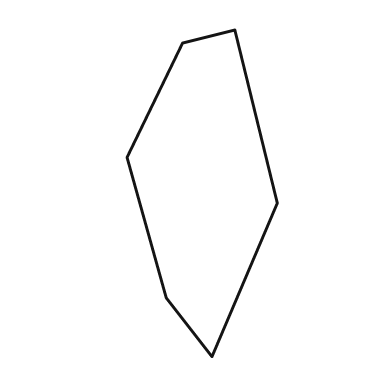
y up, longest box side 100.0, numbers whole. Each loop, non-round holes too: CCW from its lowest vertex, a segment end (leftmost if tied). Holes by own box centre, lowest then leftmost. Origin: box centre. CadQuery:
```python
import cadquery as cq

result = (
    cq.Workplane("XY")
    .moveTo(3.0, -50.0)
    .lineTo(23.0, -3.0)
    .lineTo(10.0, 50.0)
    .lineTo(-6.0, 46.0)
    .lineTo(-23.0, 11.0)
    .lineTo(-11.0, -32.0)
    .close()
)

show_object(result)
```